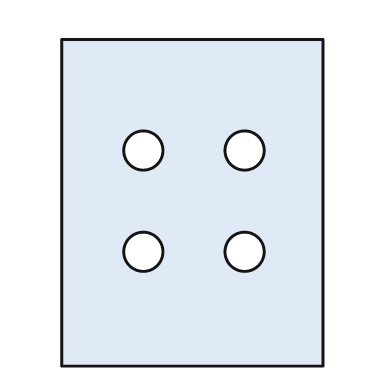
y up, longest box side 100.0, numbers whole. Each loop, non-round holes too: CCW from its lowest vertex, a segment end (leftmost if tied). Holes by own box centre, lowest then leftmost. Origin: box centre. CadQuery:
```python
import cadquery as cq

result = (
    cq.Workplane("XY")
    .moveTo(-40.0, -50.0)
    .lineTo(40.0, -50.0)
    .lineTo(40.0, 50.0)
    .lineTo(-40.0, 50.0)
    .close()
    .moveTo(-15.0, -15.0)
    .circle(6.0)
    .moveTo(16.0, -15.0)
    .circle(6.0)
    .moveTo(-15.0, 16.0)
    .circle(6.0)
    .moveTo(16.0, 16.0)
    .circle(6.0)
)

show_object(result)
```